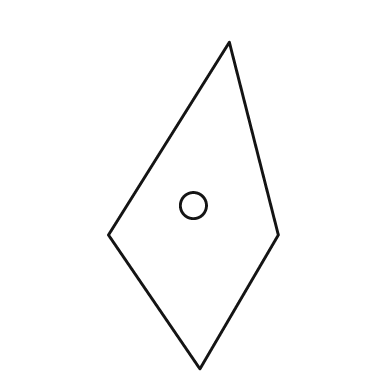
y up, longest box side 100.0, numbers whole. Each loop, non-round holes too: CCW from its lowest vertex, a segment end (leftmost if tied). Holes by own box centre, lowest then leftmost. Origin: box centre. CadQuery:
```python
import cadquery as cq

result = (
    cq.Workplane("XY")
    .moveTo(2.0, -50.0)
    .lineTo(26.0, -9.0)
    .lineTo(11.0, 50.0)
    .lineTo(-26.0, -9.0)
    .close()
    .moveTo(0.0, 0.0)
    .circle(4.0)
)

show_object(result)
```